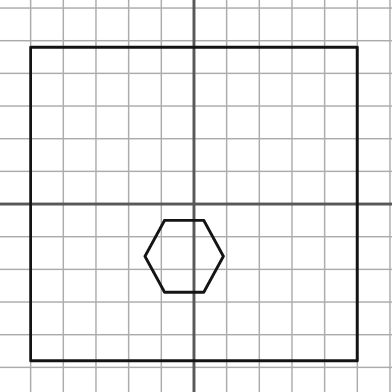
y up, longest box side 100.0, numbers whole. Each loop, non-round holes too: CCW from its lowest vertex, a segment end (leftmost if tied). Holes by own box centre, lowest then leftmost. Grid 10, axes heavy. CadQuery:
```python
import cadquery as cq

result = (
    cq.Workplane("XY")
    .moveTo(-50.0, -48.0)
    .lineTo(50.0, -48.0)
    .lineTo(50.0, 48.0)
    .lineTo(-50.0, 48.0)
    .close()
    .moveTo(-9.0, -27.0)
    .lineTo(3.0, -27.0)
    .lineTo(9.0, -16.0)
    .lineTo(3.0, -5.0)
    .lineTo(-9.0, -5.0)
    .lineTo(-15.0, -16.0)
    .close()
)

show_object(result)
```